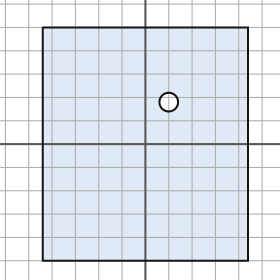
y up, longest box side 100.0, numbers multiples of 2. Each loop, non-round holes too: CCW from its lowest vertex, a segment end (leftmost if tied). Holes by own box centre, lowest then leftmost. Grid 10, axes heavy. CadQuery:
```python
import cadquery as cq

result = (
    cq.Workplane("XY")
    .moveTo(-44.0, -50.0)
    .lineTo(44.0, -50.0)
    .lineTo(44.0, 50.0)
    .lineTo(-44.0, 50.0)
    .close()
    .moveTo(10.0, 18.0)
    .circle(4.0)
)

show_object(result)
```